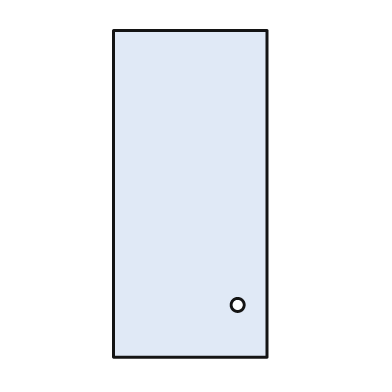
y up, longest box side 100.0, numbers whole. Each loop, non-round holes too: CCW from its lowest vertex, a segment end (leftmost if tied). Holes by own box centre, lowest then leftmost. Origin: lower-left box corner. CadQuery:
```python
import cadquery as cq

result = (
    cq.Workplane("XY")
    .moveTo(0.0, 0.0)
    .lineTo(47.0, 0.0)
    .lineTo(47.0, 100.0)
    .lineTo(0.0, 100.0)
    .close()
    .moveTo(38.0, 16.0)
    .circle(2.0)
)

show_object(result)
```